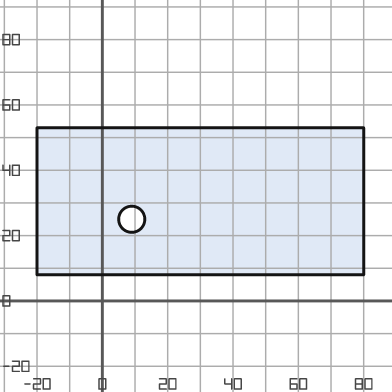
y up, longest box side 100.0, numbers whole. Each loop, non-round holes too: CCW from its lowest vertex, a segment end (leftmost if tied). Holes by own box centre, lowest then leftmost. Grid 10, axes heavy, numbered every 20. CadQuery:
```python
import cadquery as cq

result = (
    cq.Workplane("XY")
    .moveTo(-20.0, 8.0)
    .lineTo(80.0, 8.0)
    .lineTo(80.0, 53.0)
    .lineTo(-20.0, 53.0)
    .close()
    .moveTo(9.0, 25.0)
    .circle(4.0)
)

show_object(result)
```